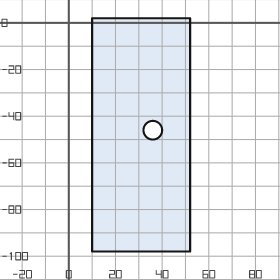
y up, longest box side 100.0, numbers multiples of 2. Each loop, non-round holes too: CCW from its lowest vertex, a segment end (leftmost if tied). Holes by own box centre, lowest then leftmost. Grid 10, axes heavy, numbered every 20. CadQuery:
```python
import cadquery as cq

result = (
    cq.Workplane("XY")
    .moveTo(10.0, -98.0)
    .lineTo(52.0, -98.0)
    .lineTo(52.0, 2.0)
    .lineTo(10.0, 2.0)
    .close()
    .moveTo(36.0, -46.0)
    .circle(4.0)
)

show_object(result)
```